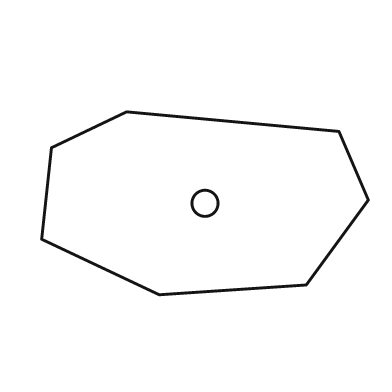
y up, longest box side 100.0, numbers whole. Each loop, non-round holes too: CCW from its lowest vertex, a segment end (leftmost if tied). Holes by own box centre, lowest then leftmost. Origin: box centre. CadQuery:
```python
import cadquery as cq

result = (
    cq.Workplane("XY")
    .moveTo(-14.0, -28.0)
    .lineTo(31.0, -25.0)
    .lineTo(50.0, 1.0)
    .lineTo(41.0, 22.0)
    .lineTo(-24.0, 28.0)
    .lineTo(-47.0, 17.0)
    .lineTo(-50.0, -11.0)
    .close()
    .moveTo(0.0, 0.0)
    .circle(4.0)
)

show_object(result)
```